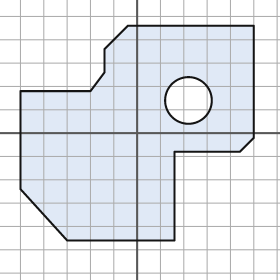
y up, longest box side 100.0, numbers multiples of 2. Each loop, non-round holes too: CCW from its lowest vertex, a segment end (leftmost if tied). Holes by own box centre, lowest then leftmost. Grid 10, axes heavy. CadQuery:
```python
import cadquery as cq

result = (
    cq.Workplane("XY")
    .moveTo(-30.0, -46.0)
    .lineTo(16.0, -46.0)
    .lineTo(16.0, -8.0)
    .lineTo(44.0, -8.0)
    .lineTo(50.0, -2.0)
    .lineTo(50.0, 46.0)
    .lineTo(-4.0, 46.0)
    .lineTo(-14.0, 36.0)
    .lineTo(-14.0, 26.0)
    .lineTo(-20.0, 18.0)
    .lineTo(-50.0, 18.0)
    .lineTo(-50.0, -24.0)
    .close()
    .moveTo(22.0, 14.0)
    .circle(10.0)
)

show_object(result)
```